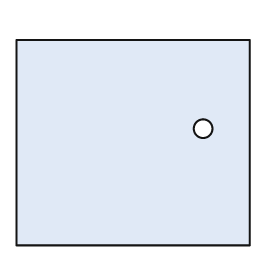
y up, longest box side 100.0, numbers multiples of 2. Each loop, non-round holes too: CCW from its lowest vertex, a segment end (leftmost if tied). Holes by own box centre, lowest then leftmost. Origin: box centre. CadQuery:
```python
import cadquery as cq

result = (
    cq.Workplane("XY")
    .moveTo(-50.0, -44.0)
    .lineTo(50.0, -44.0)
    .lineTo(50.0, 44.0)
    .lineTo(-50.0, 44.0)
    .close()
    .moveTo(30.0, 6.0)
    .circle(4.0)
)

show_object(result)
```